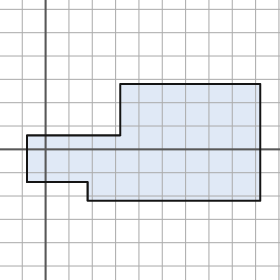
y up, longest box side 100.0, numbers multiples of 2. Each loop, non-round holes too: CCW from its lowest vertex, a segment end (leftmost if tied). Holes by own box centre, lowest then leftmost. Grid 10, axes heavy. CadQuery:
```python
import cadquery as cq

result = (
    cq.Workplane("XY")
    .moveTo(18.0, -22.0)
    .lineTo(92.0, -22.0)
    .lineTo(92.0, 28.0)
    .lineTo(32.0, 28.0)
    .lineTo(32.0, 6.0)
    .lineTo(-8.0, 6.0)
    .lineTo(-8.0, -14.0)
    .lineTo(18.0, -14.0)
    .close()
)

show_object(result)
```